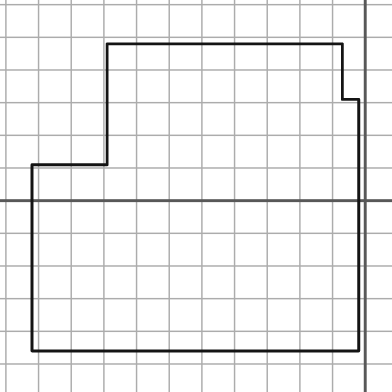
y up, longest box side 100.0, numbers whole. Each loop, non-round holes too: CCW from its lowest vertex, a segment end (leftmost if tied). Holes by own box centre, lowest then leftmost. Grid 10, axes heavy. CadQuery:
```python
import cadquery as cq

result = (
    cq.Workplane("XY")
    .moveTo(-102.0, -46.0)
    .lineTo(-2.0, -46.0)
    .lineTo(-2.0, 31.0)
    .lineTo(-7.0, 31.0)
    .lineTo(-7.0, 48.0)
    .lineTo(-79.0, 48.0)
    .lineTo(-79.0, 11.0)
    .lineTo(-102.0, 11.0)
    .close()
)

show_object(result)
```